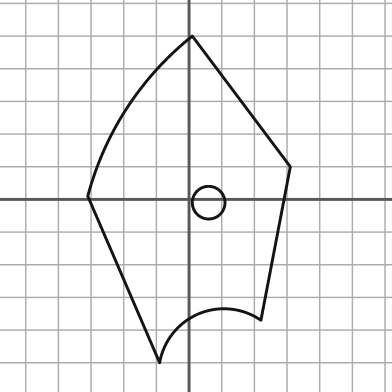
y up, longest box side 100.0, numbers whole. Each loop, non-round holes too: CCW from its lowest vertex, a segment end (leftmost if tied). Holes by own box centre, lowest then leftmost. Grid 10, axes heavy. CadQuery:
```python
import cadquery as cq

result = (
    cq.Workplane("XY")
    .moveTo(-9.0, -50.0)
    .threePointArc((3.0, -35.0), (22.0, -37.0))
    .lineTo(31.0, 10.0)
    .lineTo(1.0, 50.0)
    .threePointArc((-19.0, 28.0), (-31.0, 1.0))
    .close()
    .moveTo(6.0, -1.0)
    .circle(5.0)
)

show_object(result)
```